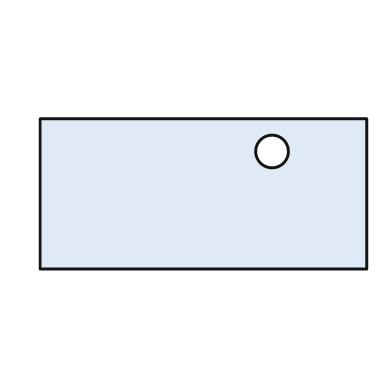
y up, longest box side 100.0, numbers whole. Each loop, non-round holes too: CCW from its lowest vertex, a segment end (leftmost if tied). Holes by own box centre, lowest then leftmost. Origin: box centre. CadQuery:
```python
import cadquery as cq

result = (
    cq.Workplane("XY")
    .moveTo(-50.0, -23.0)
    .lineTo(50.0, -23.0)
    .lineTo(50.0, 23.0)
    .lineTo(-50.0, 23.0)
    .close()
    .moveTo(21.0, 13.0)
    .circle(5.0)
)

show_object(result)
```